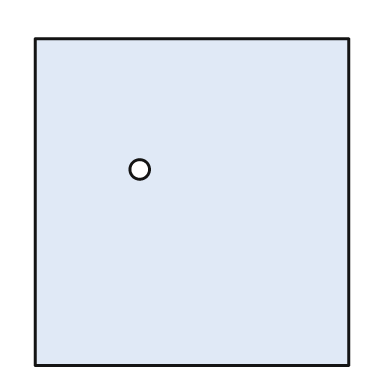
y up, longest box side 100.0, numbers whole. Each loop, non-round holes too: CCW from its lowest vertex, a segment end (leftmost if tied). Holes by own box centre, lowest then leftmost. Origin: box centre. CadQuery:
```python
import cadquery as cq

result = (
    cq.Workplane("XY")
    .moveTo(-48.0, -50.0)
    .lineTo(48.0, -50.0)
    .lineTo(48.0, 50.0)
    .lineTo(-48.0, 50.0)
    .close()
    .moveTo(-16.0, 10.0)
    .circle(3.0)
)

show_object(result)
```